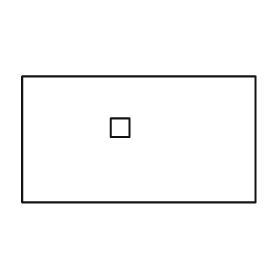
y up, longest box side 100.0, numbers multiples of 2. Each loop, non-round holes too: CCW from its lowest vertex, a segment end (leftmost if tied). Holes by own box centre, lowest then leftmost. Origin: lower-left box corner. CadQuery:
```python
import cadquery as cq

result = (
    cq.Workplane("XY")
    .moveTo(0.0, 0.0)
    .lineTo(100.0, 0.0)
    .lineTo(100.0, 54.0)
    .lineTo(0.0, 54.0)
    .close()
    .moveTo(38.0, 28.0)
    .lineTo(46.0, 28.0)
    .lineTo(46.0, 36.0)
    .lineTo(38.0, 36.0)
    .close()
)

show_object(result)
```